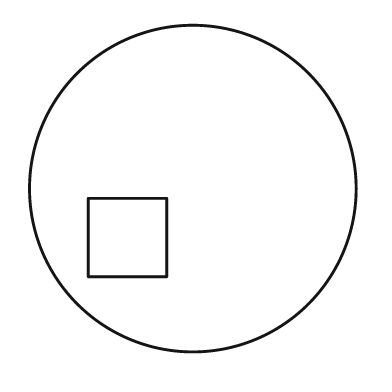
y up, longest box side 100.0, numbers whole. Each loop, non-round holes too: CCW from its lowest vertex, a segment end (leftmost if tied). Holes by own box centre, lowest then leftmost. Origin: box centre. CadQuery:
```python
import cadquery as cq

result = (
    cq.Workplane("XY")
    .moveTo(0.0, 0.0)
    .circle(50.0)
    .moveTo(-32.0, -27.0)
    .lineTo(-8.0, -27.0)
    .lineTo(-8.0, -3.0)
    .lineTo(-32.0, -3.0)
    .close()
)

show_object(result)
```